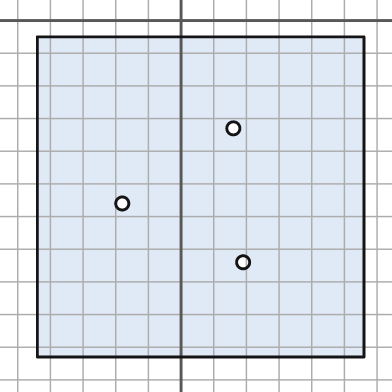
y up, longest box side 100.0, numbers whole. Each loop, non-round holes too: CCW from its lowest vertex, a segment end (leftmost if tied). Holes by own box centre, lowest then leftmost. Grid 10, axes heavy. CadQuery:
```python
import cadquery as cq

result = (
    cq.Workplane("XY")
    .moveTo(-44.0, -103.0)
    .lineTo(56.0, -103.0)
    .lineTo(56.0, -5.0)
    .lineTo(-44.0, -5.0)
    .close()
    .moveTo(19.0, -74.0)
    .circle(2.0)
    .moveTo(-18.0, -56.0)
    .circle(2.0)
    .moveTo(16.0, -33.0)
    .circle(2.0)
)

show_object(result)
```